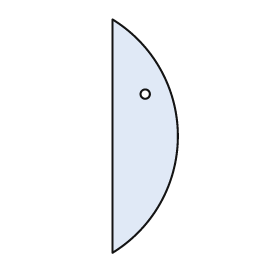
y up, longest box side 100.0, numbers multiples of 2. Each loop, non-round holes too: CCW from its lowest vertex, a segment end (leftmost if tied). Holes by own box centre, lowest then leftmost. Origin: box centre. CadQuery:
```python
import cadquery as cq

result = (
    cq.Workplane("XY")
    .moveTo(-14.0, -50.0)
    .threePointArc((14.0, 0.0), (-14.0, 50.0))
    .close()
    .moveTo(0.0, 18.0)
    .circle(2.0)
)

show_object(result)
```